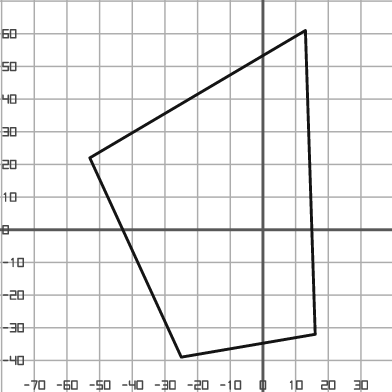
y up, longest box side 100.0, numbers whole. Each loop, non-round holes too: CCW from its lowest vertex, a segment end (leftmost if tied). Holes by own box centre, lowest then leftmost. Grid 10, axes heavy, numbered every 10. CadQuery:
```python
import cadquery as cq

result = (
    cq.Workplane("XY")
    .moveTo(-25.0, -39.0)
    .lineTo(16.0, -32.0)
    .lineTo(13.0, 61.0)
    .lineTo(-53.0, 22.0)
    .close()
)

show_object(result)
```